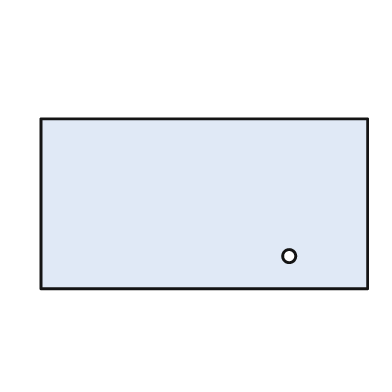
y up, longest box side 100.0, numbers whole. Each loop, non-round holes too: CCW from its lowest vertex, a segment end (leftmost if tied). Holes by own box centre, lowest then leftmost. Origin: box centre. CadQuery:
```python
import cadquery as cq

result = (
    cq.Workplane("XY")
    .moveTo(-50.0, -26.0)
    .lineTo(50.0, -26.0)
    .lineTo(50.0, 26.0)
    .lineTo(-50.0, 26.0)
    .close()
    .moveTo(26.0, -16.0)
    .circle(2.0)
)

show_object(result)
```